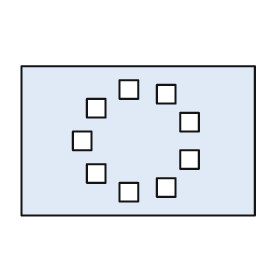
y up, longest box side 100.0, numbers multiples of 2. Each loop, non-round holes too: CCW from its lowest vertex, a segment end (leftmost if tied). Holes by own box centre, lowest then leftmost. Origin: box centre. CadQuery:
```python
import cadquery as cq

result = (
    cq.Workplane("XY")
    .moveTo(-50.0, -32.0)
    .lineTo(50.0, -32.0)
    .lineTo(50.0, 32.0)
    .lineTo(-50.0, 32.0)
    .close()
    .moveTo(-8.0, -26.0)
    .lineTo(0.0, -26.0)
    .lineTo(0.0, -18.0)
    .lineTo(-8.0, -18.0)
    .close()
    .moveTo(8.0, -24.0)
    .lineTo(16.0, -24.0)
    .lineTo(16.0, -16.0)
    .lineTo(8.0, -16.0)
    .close()
    .moveTo(-22.0, -18.0)
    .lineTo(-14.0, -18.0)
    .lineTo(-14.0, -10.0)
    .lineTo(-22.0, -10.0)
    .close()
    .moveTo(18.0, -12.0)
    .lineTo(26.0, -12.0)
    .lineTo(26.0, -4.0)
    .lineTo(18.0, -4.0)
    .close()
    .moveTo(-28.0, -4.0)
    .lineTo(-20.0, -4.0)
    .lineTo(-20.0, 4.0)
    .lineTo(-28.0, 4.0)
    .close()
    .moveTo(18.0, 4.0)
    .lineTo(26.0, 4.0)
    .lineTo(26.0, 12.0)
    .lineTo(18.0, 12.0)
    .close()
    .moveTo(-22.0, 10.0)
    .lineTo(-14.0, 10.0)
    .lineTo(-14.0, 18.0)
    .lineTo(-22.0, 18.0)
    .close()
    .moveTo(8.0, 16.0)
    .lineTo(16.0, 16.0)
    .lineTo(16.0, 24.0)
    .lineTo(8.0, 24.0)
    .close()
    .moveTo(-8.0, 18.0)
    .lineTo(0.0, 18.0)
    .lineTo(0.0, 26.0)
    .lineTo(-8.0, 26.0)
    .close()
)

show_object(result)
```